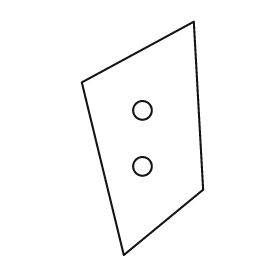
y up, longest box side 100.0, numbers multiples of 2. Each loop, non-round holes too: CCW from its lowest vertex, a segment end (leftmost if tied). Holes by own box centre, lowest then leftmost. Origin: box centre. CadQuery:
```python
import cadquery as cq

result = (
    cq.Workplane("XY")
    .moveTo(-8.0, -50.0)
    .lineTo(26.0, -22.0)
    .lineTo(22.0, 50.0)
    .lineTo(-26.0, 24.0)
    .close()
    .moveTo(0.0, -12.0)
    .circle(4.0)
    .moveTo(0.0, 12.0)
    .circle(4.0)
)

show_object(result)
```